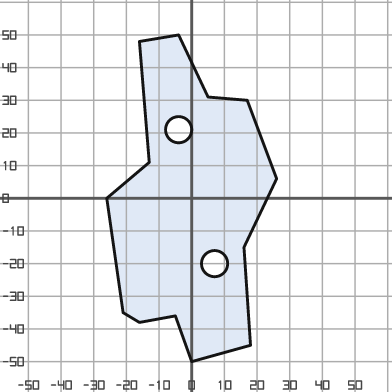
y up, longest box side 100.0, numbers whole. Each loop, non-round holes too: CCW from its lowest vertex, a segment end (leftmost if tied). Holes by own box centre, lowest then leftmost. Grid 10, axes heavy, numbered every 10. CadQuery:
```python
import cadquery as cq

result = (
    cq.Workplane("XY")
    .moveTo(0.0, -50.0)
    .lineTo(18.0, -45.0)
    .lineTo(16.0, -15.0)
    .lineTo(26.0, 6.0)
    .lineTo(17.0, 30.0)
    .lineTo(5.0, 31.0)
    .lineTo(-4.0, 50.0)
    .lineTo(-16.0, 48.0)
    .lineTo(-13.0, 11.0)
    .lineTo(-26.0, 0.0)
    .lineTo(-21.0, -35.0)
    .lineTo(-16.0, -38.0)
    .lineTo(-5.0, -36.0)
    .close()
    .moveTo(7.0, -20.0)
    .circle(4.0)
    .moveTo(-4.0, 21.0)
    .circle(4.0)
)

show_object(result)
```